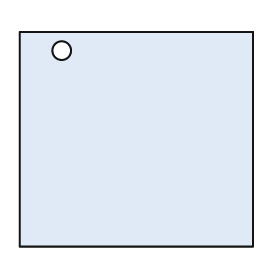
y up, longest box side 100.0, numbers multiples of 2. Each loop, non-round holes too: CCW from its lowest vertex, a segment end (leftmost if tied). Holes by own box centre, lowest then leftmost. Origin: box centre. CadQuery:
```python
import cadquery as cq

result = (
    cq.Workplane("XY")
    .moveTo(-50.0, -46.0)
    .lineTo(50.0, -46.0)
    .lineTo(50.0, 46.0)
    .lineTo(-50.0, 46.0)
    .close()
    .moveTo(-32.0, 38.0)
    .circle(4.0)
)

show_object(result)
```